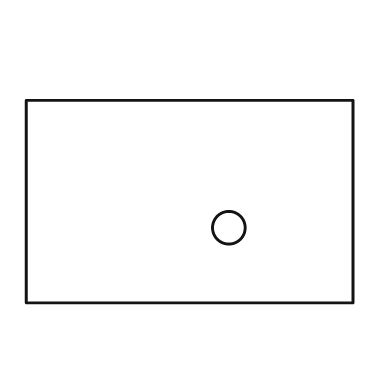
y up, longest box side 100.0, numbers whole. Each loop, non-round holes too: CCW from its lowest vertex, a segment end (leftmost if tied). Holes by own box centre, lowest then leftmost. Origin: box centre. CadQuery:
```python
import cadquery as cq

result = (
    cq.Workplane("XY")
    .moveTo(-50.0, -31.0)
    .lineTo(50.0, -31.0)
    .lineTo(50.0, 31.0)
    .lineTo(-50.0, 31.0)
    .close()
    .moveTo(12.0, -8.0)
    .circle(5.0)
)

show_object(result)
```